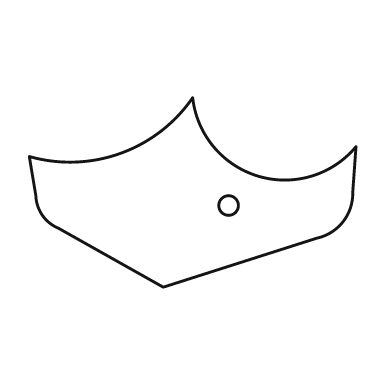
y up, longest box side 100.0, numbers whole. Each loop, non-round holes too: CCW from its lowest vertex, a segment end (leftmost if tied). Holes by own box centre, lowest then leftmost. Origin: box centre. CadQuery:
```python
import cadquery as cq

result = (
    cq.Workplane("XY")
    .moveTo(-9.0, -29.0)
    .lineTo(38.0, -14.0)
    .threePointArc((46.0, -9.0), (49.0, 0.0))
    .lineTo(50.0, 14.0)
    .threePointArc((20.0, 5.0), (0.0, 29.0))
    .threePointArc((-22.0, 12.0), (-50.0, 11.0))
    .lineTo(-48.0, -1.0)
    .threePointArc((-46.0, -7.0), (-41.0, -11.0))
    .close()
    .moveTo(11.0, -4.0)
    .circle(3.0)
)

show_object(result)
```